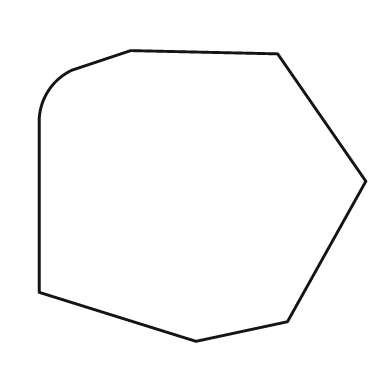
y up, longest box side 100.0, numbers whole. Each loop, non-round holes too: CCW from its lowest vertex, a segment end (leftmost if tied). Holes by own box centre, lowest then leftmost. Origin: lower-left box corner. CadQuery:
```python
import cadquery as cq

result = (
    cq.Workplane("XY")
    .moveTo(48.0, 0.0)
    .lineTo(76.0, 6.0)
    .lineTo(100.0, 49.0)
    .lineTo(73.0, 88.0)
    .lineTo(28.0, 89.0)
    .lineTo(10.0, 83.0)
    .threePointArc((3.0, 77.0), (0.0, 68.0))
    .lineTo(0.0, 15.0)
    .close()
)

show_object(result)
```